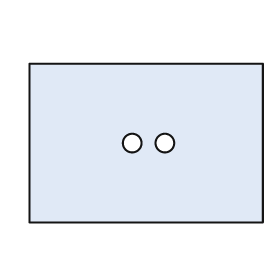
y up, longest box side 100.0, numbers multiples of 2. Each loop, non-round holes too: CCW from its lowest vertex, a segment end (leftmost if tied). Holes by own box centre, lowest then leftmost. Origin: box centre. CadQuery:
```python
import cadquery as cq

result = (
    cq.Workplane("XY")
    .moveTo(-50.0, -34.0)
    .lineTo(50.0, -34.0)
    .lineTo(50.0, 34.0)
    .lineTo(-50.0, 34.0)
    .close()
    .moveTo(-6.0, 0.0)
    .circle(4.0)
    .moveTo(8.0, 0.0)
    .circle(4.0)
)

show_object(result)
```